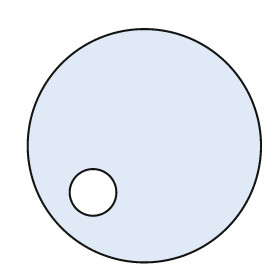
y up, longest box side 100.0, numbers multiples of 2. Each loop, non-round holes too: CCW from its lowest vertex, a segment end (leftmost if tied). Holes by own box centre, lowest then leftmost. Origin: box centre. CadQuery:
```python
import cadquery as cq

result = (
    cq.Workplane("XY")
    .moveTo(0.0, 0.0)
    .circle(50.0)
    .moveTo(-22.0, -20.0)
    .circle(10.0)
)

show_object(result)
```